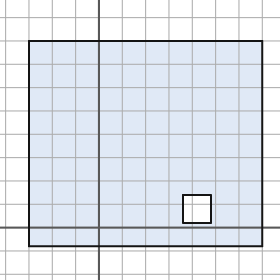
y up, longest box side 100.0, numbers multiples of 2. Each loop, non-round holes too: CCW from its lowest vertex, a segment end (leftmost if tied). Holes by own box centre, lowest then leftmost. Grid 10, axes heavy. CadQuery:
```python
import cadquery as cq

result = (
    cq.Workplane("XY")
    .moveTo(-30.0, -8.0)
    .lineTo(70.0, -8.0)
    .lineTo(70.0, 80.0)
    .lineTo(-30.0, 80.0)
    .close()
    .moveTo(36.0, 2.0)
    .lineTo(48.0, 2.0)
    .lineTo(48.0, 14.0)
    .lineTo(36.0, 14.0)
    .close()
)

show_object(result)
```